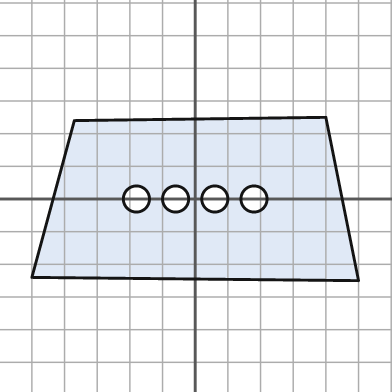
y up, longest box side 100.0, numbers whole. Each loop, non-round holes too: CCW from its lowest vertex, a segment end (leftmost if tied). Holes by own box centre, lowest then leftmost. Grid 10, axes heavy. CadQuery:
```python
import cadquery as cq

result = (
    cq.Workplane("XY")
    .moveTo(50.0, -25.0)
    .lineTo(40.0, 25.0)
    .lineTo(-37.0, 24.0)
    .lineTo(-50.0, -24.0)
    .close()
    .moveTo(-18.0, 0.0)
    .circle(4.0)
    .moveTo(-6.0, 0.0)
    .circle(4.0)
    .moveTo(6.0, 0.0)
    .circle(4.0)
    .moveTo(18.0, 0.0)
    .circle(4.0)
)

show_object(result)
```